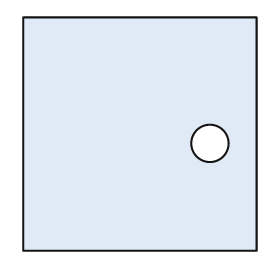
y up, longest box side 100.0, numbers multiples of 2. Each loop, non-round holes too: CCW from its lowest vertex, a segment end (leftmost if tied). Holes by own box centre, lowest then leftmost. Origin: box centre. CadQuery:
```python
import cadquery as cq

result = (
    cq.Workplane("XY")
    .moveTo(-50.0, -50.0)
    .lineTo(50.0, -50.0)
    .lineTo(50.0, 50.0)
    .lineTo(-50.0, 50.0)
    .close()
    .moveTo(30.0, -4.0)
    .circle(8.0)
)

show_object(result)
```